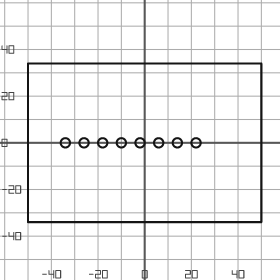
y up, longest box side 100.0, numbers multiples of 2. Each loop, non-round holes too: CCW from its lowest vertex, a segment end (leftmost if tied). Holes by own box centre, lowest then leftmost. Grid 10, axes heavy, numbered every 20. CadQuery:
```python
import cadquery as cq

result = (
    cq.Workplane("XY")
    .moveTo(-50.0, -34.0)
    .lineTo(50.0, -34.0)
    .lineTo(50.0, 34.0)
    .lineTo(-50.0, 34.0)
    .close()
    .moveTo(-34.0, 0.0)
    .circle(2.0)
    .moveTo(-26.0, 0.0)
    .circle(2.0)
    .moveTo(-18.0, 0.0)
    .circle(2.0)
    .moveTo(-10.0, 0.0)
    .circle(2.0)
    .moveTo(-2.0, 0.0)
    .circle(2.0)
    .moveTo(6.0, 0.0)
    .circle(2.0)
    .moveTo(14.0, 0.0)
    .circle(2.0)
    .moveTo(22.0, 0.0)
    .circle(2.0)
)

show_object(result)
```